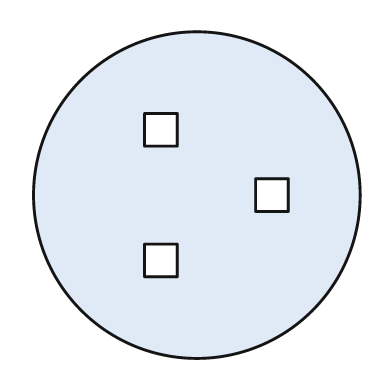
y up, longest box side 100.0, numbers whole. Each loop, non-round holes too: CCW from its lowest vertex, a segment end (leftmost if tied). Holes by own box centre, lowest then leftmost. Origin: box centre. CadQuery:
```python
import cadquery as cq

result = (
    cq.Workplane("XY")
    .moveTo(0.0, 0.0)
    .circle(50.0)
    .moveTo(-16.0, -25.0)
    .lineTo(-6.0, -25.0)
    .lineTo(-6.0, -15.0)
    .lineTo(-16.0, -15.0)
    .close()
    .moveTo(18.0, -5.0)
    .lineTo(28.0, -5.0)
    .lineTo(28.0, 5.0)
    .lineTo(18.0, 5.0)
    .close()
    .moveTo(-16.0, 15.0)
    .lineTo(-6.0, 15.0)
    .lineTo(-6.0, 25.0)
    .lineTo(-16.0, 25.0)
    .close()
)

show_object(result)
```